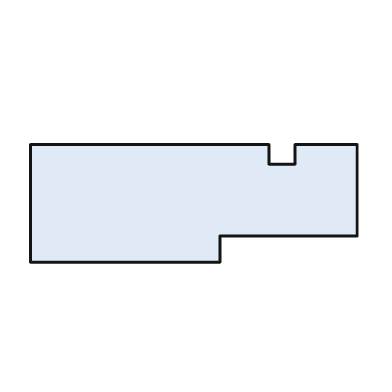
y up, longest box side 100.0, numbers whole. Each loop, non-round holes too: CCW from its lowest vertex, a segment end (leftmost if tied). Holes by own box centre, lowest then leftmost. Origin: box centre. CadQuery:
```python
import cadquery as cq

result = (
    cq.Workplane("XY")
    .moveTo(-50.0, -18.0)
    .lineTo(8.0, -18.0)
    .lineTo(8.0, -10.0)
    .lineTo(50.0, -10.0)
    .lineTo(50.0, 18.0)
    .lineTo(31.0, 18.0)
    .lineTo(31.0, 12.0)
    .lineTo(23.0, 12.0)
    .lineTo(23.0, 18.0)
    .lineTo(-50.0, 18.0)
    .close()
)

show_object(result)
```